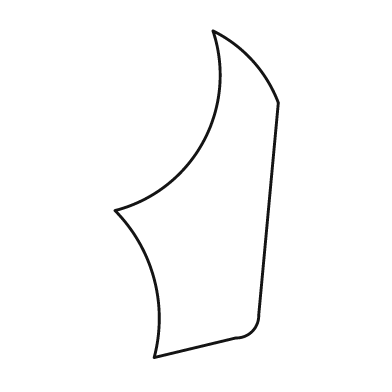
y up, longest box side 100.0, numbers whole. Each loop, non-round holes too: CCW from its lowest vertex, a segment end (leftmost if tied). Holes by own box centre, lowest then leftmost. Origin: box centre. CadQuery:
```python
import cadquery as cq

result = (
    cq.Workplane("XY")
    .moveTo(-13.0, -50.0)
    .lineTo(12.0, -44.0)
    .threePointArc((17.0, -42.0), (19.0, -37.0))
    .lineTo(25.0, 28.0)
    .threePointArc((17.0, 41.0), (5.0, 50.0))
    .threePointArc((2.0, 16.0), (-25.0, -5.0))
    .threePointArc((-13.0, -26.0), (-13.0, -50.0))
    .close()
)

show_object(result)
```